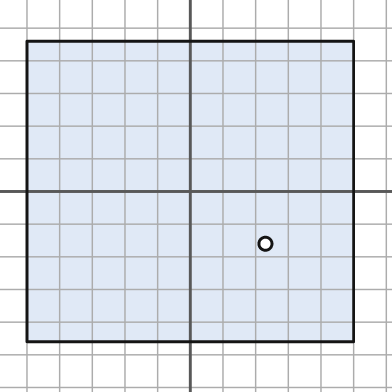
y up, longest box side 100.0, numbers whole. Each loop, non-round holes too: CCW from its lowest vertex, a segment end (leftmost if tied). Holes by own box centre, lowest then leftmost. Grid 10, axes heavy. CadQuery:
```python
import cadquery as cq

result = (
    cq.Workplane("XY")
    .moveTo(-50.0, -46.0)
    .lineTo(50.0, -46.0)
    .lineTo(50.0, 46.0)
    .lineTo(-50.0, 46.0)
    .close()
    .moveTo(23.0, -16.0)
    .circle(2.0)
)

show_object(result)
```